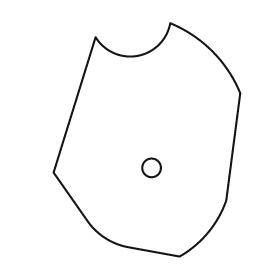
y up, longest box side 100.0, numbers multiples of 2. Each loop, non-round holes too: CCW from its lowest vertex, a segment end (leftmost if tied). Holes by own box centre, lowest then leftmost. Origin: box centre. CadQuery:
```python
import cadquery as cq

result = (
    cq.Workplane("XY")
    .moveTo(14.0, -50.0)
    .threePointArc((26.0, -40.0), (34.0, -26.0))
    .lineTo(40.0, 20.0)
    .threePointArc((28.0, 38.0), (10.0, 50.0))
    .threePointArc((-4.0, 36.0), (-22.0, 44.0))
    .lineTo(-40.0, -14.0)
    .lineTo(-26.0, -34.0)
    .threePointArc((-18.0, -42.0), (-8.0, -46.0))
    .close()
    .moveTo(2.0, -12.0)
    .circle(4.0)
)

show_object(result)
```